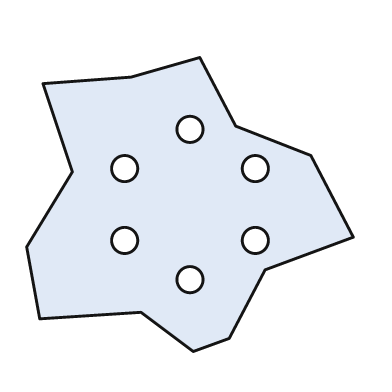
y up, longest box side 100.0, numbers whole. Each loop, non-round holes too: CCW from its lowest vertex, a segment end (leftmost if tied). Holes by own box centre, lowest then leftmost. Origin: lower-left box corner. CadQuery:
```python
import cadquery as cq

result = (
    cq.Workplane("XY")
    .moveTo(51.0, 0.0)
    .lineTo(62.0, 4.0)
    .lineTo(73.0, 25.0)
    .lineTo(100.0, 35.0)
    .lineTo(87.0, 60.0)
    .lineTo(64.0, 69.0)
    .lineTo(53.0, 90.0)
    .lineTo(32.0, 84.0)
    .lineTo(5.0, 82.0)
    .lineTo(14.0, 55.0)
    .lineTo(0.0, 32.0)
    .lineTo(4.0, 10.0)
    .lineTo(35.0, 12.0)
    .close()
    .moveTo(50.0, 22.0)
    .circle(4.0)
    .moveTo(30.0, 34.0)
    .circle(4.0)
    .moveTo(70.0, 34.0)
    .circle(4.0)
    .moveTo(30.0, 56.0)
    .circle(4.0)
    .moveTo(70.0, 56.0)
    .circle(4.0)
    .moveTo(50.0, 68.0)
    .circle(4.0)
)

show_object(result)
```